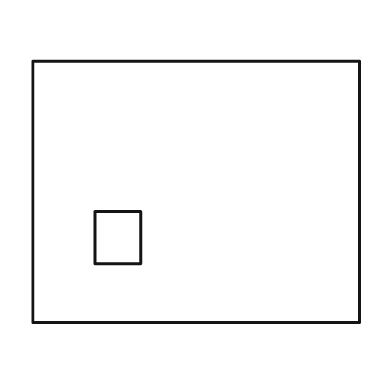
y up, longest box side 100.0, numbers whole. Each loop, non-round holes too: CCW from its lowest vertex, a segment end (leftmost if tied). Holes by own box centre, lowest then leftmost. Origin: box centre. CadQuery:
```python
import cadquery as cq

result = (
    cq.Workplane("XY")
    .moveTo(-50.0, -40.0)
    .lineTo(50.0, -40.0)
    .lineTo(50.0, 40.0)
    .lineTo(-50.0, 40.0)
    .close()
    .moveTo(-31.0, -22.0)
    .lineTo(-17.0, -22.0)
    .lineTo(-17.0, -6.0)
    .lineTo(-31.0, -6.0)
    .close()
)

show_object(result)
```